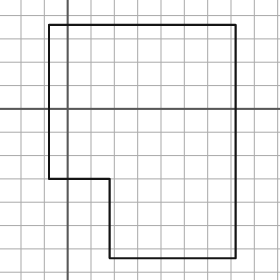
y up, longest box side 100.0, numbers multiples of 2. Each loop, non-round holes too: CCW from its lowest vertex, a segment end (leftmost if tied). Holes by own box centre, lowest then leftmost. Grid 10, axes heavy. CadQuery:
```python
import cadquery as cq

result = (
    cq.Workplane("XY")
    .moveTo(18.0, -64.0)
    .lineTo(72.0, -64.0)
    .lineTo(72.0, 36.0)
    .lineTo(-8.0, 36.0)
    .lineTo(-8.0, -30.0)
    .lineTo(18.0, -30.0)
    .close()
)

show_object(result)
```